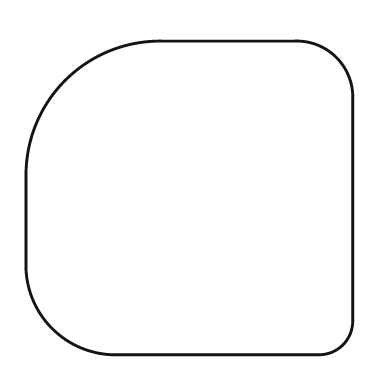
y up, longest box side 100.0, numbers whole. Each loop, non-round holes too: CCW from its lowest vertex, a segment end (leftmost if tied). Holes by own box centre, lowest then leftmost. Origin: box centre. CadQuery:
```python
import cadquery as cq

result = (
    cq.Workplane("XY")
    .moveTo(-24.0, -48.0)
    .lineTo(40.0, -48.0)
    .threePointArc((47.0, -45.0), (50.0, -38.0))
    .lineTo(50.0, 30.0)
    .threePointArc((45.0, 43.0), (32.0, 48.0))
    .lineTo(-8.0, 48.0)
    .threePointArc((-38.0, 36.0), (-50.0, 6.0))
    .lineTo(-50.0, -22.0)
    .threePointArc((-42.0, -40.0), (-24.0, -48.0))
    .close()
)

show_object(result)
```